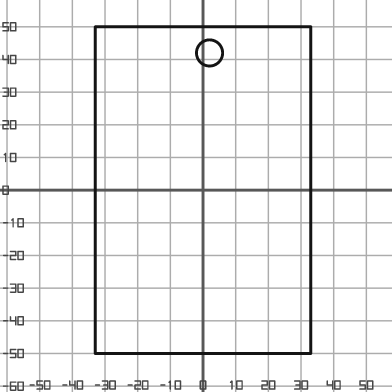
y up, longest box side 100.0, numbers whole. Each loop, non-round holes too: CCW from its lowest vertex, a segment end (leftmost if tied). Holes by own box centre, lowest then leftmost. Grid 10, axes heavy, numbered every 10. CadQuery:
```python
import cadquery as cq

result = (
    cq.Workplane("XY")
    .moveTo(-33.0, -50.0)
    .lineTo(33.0, -50.0)
    .lineTo(33.0, 50.0)
    .lineTo(-33.0, 50.0)
    .close()
    .moveTo(2.0, 42.0)
    .circle(4.0)
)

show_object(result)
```